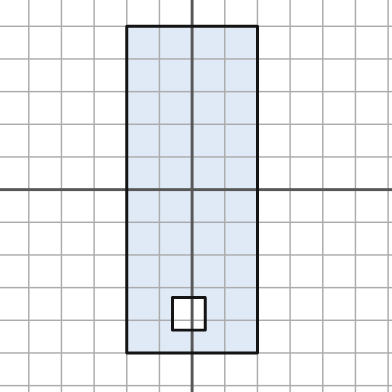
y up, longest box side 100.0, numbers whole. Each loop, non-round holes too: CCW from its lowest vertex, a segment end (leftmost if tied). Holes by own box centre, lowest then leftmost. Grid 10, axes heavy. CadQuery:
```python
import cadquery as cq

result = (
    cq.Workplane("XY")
    .moveTo(-20.0, -50.0)
    .lineTo(20.0, -50.0)
    .lineTo(20.0, 50.0)
    .lineTo(-20.0, 50.0)
    .close()
    .moveTo(-6.0, -43.0)
    .lineTo(4.0, -43.0)
    .lineTo(4.0, -33.0)
    .lineTo(-6.0, -33.0)
    .close()
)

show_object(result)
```